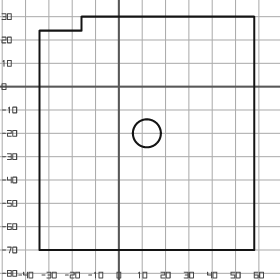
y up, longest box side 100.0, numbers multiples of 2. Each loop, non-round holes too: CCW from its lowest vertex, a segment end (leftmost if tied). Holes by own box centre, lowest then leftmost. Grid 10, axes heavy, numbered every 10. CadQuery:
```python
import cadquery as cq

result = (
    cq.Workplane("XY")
    .moveTo(-34.0, -70.0)
    .lineTo(58.0, -70.0)
    .lineTo(58.0, 30.0)
    .lineTo(-16.0, 30.0)
    .lineTo(-16.0, 24.0)
    .lineTo(-34.0, 24.0)
    .close()
    .moveTo(12.0, -20.0)
    .circle(6.0)
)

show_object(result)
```